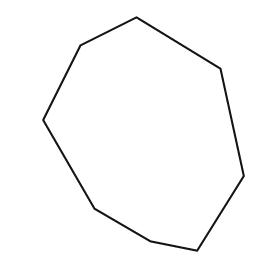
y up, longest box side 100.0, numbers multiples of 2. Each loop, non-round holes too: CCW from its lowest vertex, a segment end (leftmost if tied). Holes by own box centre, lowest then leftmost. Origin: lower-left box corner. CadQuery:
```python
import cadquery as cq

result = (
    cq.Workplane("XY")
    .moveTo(66.0, 0.0)
    .lineTo(86.0, 32.0)
    .lineTo(76.0, 78.0)
    .lineTo(40.0, 100.0)
    .lineTo(16.0, 88.0)
    .lineTo(0.0, 56.0)
    .lineTo(22.0, 18.0)
    .lineTo(46.0, 4.0)
    .close()
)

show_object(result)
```